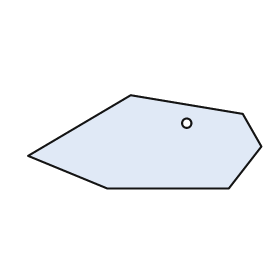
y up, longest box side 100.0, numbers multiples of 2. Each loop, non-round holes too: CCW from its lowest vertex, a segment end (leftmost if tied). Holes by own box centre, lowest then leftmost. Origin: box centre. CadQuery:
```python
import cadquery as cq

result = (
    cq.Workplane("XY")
    .moveTo(-16.0, -20.0)
    .lineTo(36.0, -20.0)
    .lineTo(50.0, -2.0)
    .lineTo(42.0, 12.0)
    .lineTo(-6.0, 20.0)
    .lineTo(-50.0, -6.0)
    .close()
    .moveTo(18.0, 8.0)
    .circle(2.0)
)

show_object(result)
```